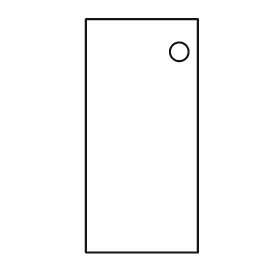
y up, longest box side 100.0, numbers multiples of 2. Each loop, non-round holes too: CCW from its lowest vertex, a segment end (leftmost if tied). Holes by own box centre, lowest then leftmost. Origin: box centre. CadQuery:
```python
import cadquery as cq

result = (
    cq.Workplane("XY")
    .moveTo(-24.0, -50.0)
    .lineTo(24.0, -50.0)
    .lineTo(24.0, 50.0)
    .lineTo(-24.0, 50.0)
    .close()
    .moveTo(16.0, 36.0)
    .circle(4.0)
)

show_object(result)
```